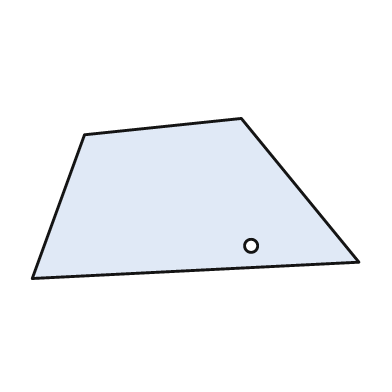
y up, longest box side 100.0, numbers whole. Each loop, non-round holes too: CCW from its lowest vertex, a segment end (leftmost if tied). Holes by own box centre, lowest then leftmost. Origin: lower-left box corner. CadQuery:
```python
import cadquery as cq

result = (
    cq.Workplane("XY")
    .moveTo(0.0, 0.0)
    .lineTo(100.0, 5.0)
    .lineTo(64.0, 49.0)
    .lineTo(16.0, 44.0)
    .close()
    .moveTo(67.0, 10.0)
    .circle(2.0)
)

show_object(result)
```